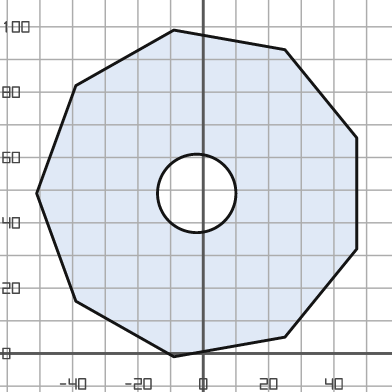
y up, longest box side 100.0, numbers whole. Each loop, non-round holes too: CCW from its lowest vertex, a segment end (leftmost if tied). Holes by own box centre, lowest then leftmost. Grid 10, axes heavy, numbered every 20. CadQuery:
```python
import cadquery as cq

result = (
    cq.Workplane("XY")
    .moveTo(-9.0, -1.0)
    .lineTo(25.0, 5.0)
    .lineTo(47.0, 32.0)
    .lineTo(47.0, 66.0)
    .lineTo(25.0, 93.0)
    .lineTo(-9.0, 99.0)
    .lineTo(-39.0, 82.0)
    .lineTo(-51.0, 49.0)
    .lineTo(-39.0, 16.0)
    .close()
    .moveTo(-2.0, 49.0)
    .circle(12.0)
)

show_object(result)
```